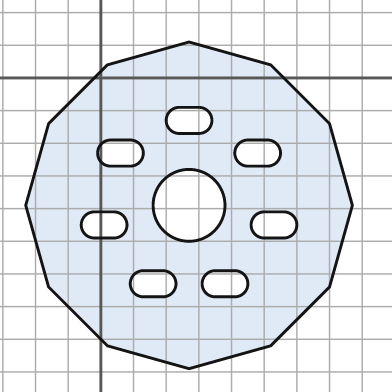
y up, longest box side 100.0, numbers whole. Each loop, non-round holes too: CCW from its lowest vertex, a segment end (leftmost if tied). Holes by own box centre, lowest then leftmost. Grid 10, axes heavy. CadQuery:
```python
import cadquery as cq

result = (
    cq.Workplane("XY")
    .moveTo(27.0, -89.0)
    .lineTo(52.0, -82.0)
    .lineTo(70.0, -64.0)
    .lineTo(77.0, -39.0)
    .lineTo(70.0, -14.0)
    .lineTo(52.0, 4.0)
    .lineTo(27.0, 11.0)
    .lineTo(2.0, 4.0)
    .lineTo(-16.0, -14.0)
    .lineTo(-23.0, -39.0)
    .lineTo(-16.0, -64.0)
    .lineTo(2.0, -82.0)
    .close()
    .moveTo(13.0, -67.0)
    .lineTo(19.0, -67.0)
    .threePointArc((23.0, -63.0), (19.0, -59.0))
    .lineTo(13.0, -59.0)
    .threePointArc((9.0, -63.0), (13.0, -67.0))
    .close()
    .moveTo(35.0, -67.0)
    .lineTo(41.0, -67.0)
    .threePointArc((45.0, -63.0), (41.0, -59.0))
    .lineTo(35.0, -59.0)
    .threePointArc((31.0, -63.0), (35.0, -67.0))
    .close()
    .moveTo(-2.0, -49.0)
    .lineTo(4.0, -49.0)
    .threePointArc((8.0, -45.0), (4.0, -41.0))
    .lineTo(-2.0, -41.0)
    .threePointArc((-6.0, -45.0), (-2.0, -49.0))
    .close()
    .moveTo(50.0, -49.0)
    .lineTo(56.0, -49.0)
    .threePointArc((60.0, -45.0), (56.0, -41.0))
    .lineTo(50.0, -41.0)
    .threePointArc((46.0, -45.0), (50.0, -49.0))
    .close()
    .moveTo(27.0, -39.0)
    .circle(11.0)
    .moveTo(3.0, -27.0)
    .lineTo(9.0, -27.0)
    .threePointArc((13.0, -23.0), (9.0, -19.0))
    .lineTo(3.0, -19.0)
    .threePointArc((-1.0, -23.0), (3.0, -27.0))
    .close()
    .moveTo(45.0, -27.0)
    .lineTo(51.0, -27.0)
    .threePointArc((55.0, -23.0), (51.0, -19.0))
    .lineTo(45.0, -19.0)
    .threePointArc((41.0, -23.0), (45.0, -27.0))
    .close()
    .moveTo(24.0, -17.0)
    .lineTo(30.0, -17.0)
    .threePointArc((34.0, -13.0), (30.0, -9.0))
    .lineTo(24.0, -9.0)
    .threePointArc((20.0, -13.0), (24.0, -17.0))
    .close()
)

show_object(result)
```